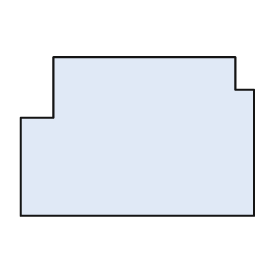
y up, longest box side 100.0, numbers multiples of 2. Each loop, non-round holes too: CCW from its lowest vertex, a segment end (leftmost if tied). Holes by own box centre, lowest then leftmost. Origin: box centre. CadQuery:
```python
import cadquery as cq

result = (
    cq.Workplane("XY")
    .moveTo(-50.0, -34.0)
    .lineTo(50.0, -34.0)
    .lineTo(50.0, 20.0)
    .lineTo(42.0, 20.0)
    .lineTo(42.0, 34.0)
    .lineTo(-36.0, 34.0)
    .lineTo(-36.0, 8.0)
    .lineTo(-50.0, 8.0)
    .close()
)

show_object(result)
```